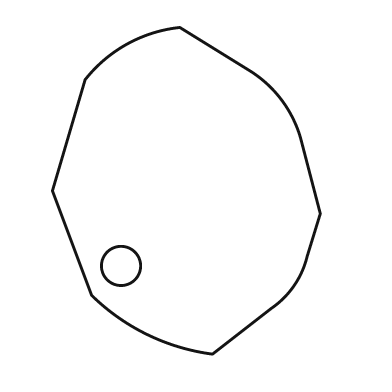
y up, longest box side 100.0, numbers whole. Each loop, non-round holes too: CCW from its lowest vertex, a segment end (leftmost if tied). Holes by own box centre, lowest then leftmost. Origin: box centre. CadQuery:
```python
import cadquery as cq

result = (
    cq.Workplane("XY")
    .moveTo(8.0, -50.0)
    .lineTo(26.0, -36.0)
    .threePointArc((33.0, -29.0), (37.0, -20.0))
    .lineTo(41.0, -7.0)
    .lineTo(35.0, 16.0)
    .threePointArc((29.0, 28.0), (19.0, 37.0))
    .lineTo(-2.0, 50.0)
    .threePointArc((-18.0, 45.0), (-31.0, 34.0))
    .lineTo(-41.0, 0.0)
    .lineTo(-29.0, -32.0)
    .threePointArc((-12.0, -44.0), (8.0, -50.0))
    .close()
    .moveTo(-20.0, -23.0)
    .circle(6.0)
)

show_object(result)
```